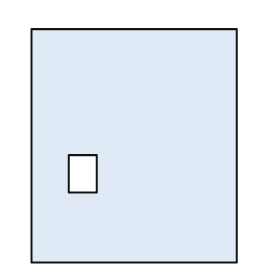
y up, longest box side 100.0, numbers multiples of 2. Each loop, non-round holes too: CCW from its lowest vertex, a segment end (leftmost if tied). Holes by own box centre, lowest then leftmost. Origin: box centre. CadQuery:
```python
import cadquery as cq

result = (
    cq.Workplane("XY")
    .moveTo(-44.0, -50.0)
    .lineTo(44.0, -50.0)
    .lineTo(44.0, 50.0)
    .lineTo(-44.0, 50.0)
    .close()
    .moveTo(-28.0, -20.0)
    .lineTo(-16.0, -20.0)
    .lineTo(-16.0, -4.0)
    .lineTo(-28.0, -4.0)
    .close()
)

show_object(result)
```